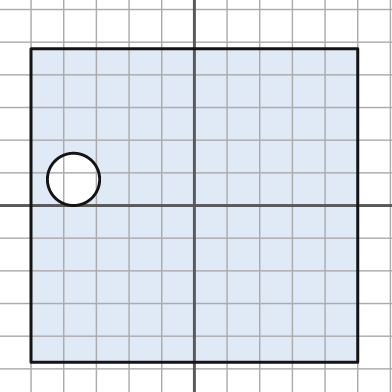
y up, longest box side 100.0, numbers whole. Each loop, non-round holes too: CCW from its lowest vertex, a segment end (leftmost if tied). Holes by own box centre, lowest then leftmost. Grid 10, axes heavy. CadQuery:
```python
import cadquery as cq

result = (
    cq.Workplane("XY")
    .moveTo(-50.0, -48.0)
    .lineTo(50.0, -48.0)
    .lineTo(50.0, 48.0)
    .lineTo(-50.0, 48.0)
    .close()
    .moveTo(-37.0, 8.0)
    .circle(8.0)
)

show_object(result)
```